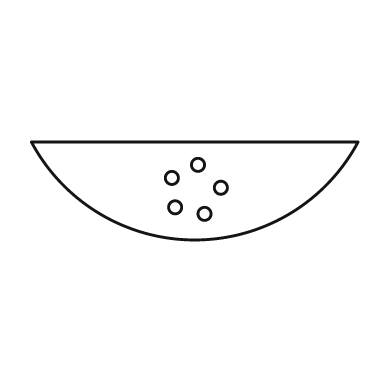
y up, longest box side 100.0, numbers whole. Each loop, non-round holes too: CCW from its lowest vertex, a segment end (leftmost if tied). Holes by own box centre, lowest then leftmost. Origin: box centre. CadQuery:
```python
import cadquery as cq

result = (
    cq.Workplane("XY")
    .moveTo(-50.0, 15.0)
    .threePointArc((0.0, -15.0), (50.0, 15.0))
    .close()
    .moveTo(3.0, -7.0)
    .circle(2.0)
    .moveTo(-6.0, -5.0)
    .circle(2.0)
    .moveTo(8.0, 1.0)
    .circle(2.0)
    .moveTo(-7.0, 4.0)
    .circle(2.0)
    .moveTo(1.0, 8.0)
    .circle(2.0)
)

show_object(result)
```